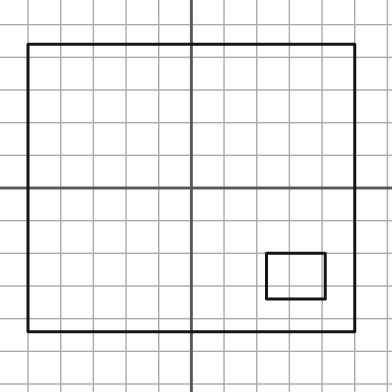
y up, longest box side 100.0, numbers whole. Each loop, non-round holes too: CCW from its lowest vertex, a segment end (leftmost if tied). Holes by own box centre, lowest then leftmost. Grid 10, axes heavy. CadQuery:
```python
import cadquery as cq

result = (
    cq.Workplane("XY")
    .moveTo(-50.0, -44.0)
    .lineTo(50.0, -44.0)
    .lineTo(50.0, 44.0)
    .lineTo(-50.0, 44.0)
    .close()
    .moveTo(23.0, -34.0)
    .lineTo(41.0, -34.0)
    .lineTo(41.0, -20.0)
    .lineTo(23.0, -20.0)
    .close()
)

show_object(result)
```